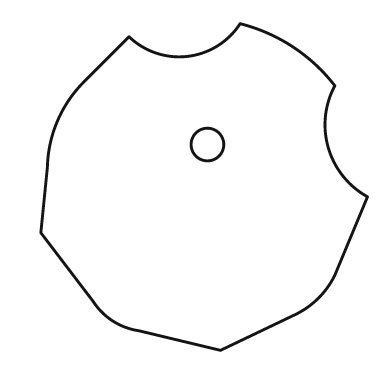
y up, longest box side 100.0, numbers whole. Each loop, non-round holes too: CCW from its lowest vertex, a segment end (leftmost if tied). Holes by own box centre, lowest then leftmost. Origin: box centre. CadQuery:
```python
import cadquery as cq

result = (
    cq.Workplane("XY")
    .moveTo(5.0, -50.0)
    .lineTo(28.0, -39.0)
    .threePointArc((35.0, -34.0), (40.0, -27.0))
    .lineTo(50.0, -3.0)
    .threePointArc((38.0, 12.0), (40.0, 31.0))
    .threePointArc((27.0, 43.0), (11.0, 50.0))
    .threePointArc((-5.0, 40.0), (-23.0, 46.0))
    .lineTo(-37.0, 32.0)
    .threePointArc((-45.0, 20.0), (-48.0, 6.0))
    .lineTo(-50.0, -14.0)
    .lineTo(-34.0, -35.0)
    .threePointArc((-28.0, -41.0), (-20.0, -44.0))
    .close()
    .moveTo(1.0, 13.0)
    .circle(5.0)
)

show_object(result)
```